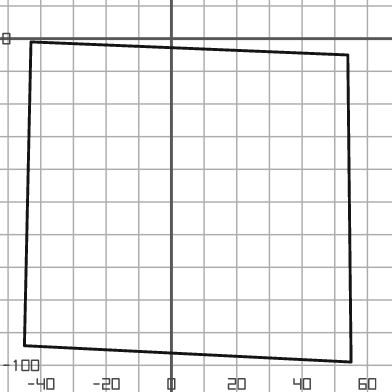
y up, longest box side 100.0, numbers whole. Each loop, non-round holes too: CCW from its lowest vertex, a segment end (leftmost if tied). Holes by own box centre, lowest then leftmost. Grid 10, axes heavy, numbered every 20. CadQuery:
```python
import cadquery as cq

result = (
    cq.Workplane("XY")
    .moveTo(55.0, -99.0)
    .lineTo(54.0, -5.0)
    .lineTo(-43.0, -1.0)
    .lineTo(-45.0, -94.0)
    .close()
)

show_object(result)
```